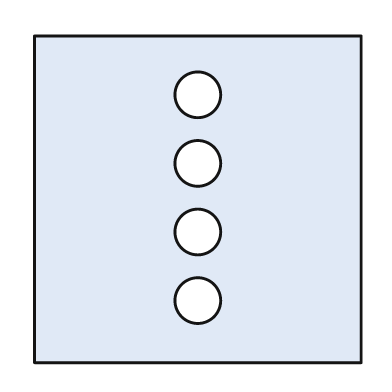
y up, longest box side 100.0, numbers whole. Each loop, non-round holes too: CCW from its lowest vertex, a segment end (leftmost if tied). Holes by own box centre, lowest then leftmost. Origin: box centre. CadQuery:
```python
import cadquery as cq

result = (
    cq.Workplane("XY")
    .moveTo(-50.0, -50.0)
    .lineTo(50.0, -50.0)
    .lineTo(50.0, 50.0)
    .lineTo(-50.0, 50.0)
    .close()
    .moveTo(0.0, -31.0)
    .circle(7.0)
    .moveTo(0.0, -10.0)
    .circle(7.0)
    .moveTo(0.0, 11.0)
    .circle(7.0)
    .moveTo(0.0, 32.0)
    .circle(7.0)
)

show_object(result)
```